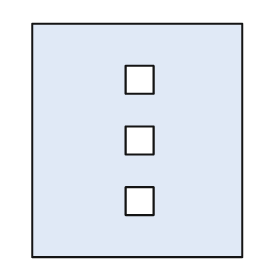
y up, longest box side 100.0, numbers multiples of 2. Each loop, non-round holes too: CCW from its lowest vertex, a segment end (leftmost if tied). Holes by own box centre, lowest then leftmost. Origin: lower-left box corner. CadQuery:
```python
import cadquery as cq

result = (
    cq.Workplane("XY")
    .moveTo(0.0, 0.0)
    .lineTo(90.0, 0.0)
    .lineTo(90.0, 100.0)
    .lineTo(0.0, 100.0)
    .close()
    .moveTo(40.0, 18.0)
    .lineTo(52.0, 18.0)
    .lineTo(52.0, 30.0)
    .lineTo(40.0, 30.0)
    .close()
    .moveTo(40.0, 44.0)
    .lineTo(52.0, 44.0)
    .lineTo(52.0, 56.0)
    .lineTo(40.0, 56.0)
    .close()
    .moveTo(40.0, 70.0)
    .lineTo(52.0, 70.0)
    .lineTo(52.0, 82.0)
    .lineTo(40.0, 82.0)
    .close()
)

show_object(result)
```